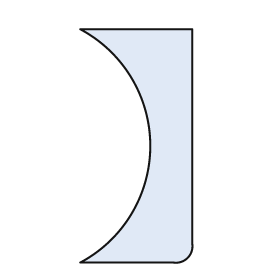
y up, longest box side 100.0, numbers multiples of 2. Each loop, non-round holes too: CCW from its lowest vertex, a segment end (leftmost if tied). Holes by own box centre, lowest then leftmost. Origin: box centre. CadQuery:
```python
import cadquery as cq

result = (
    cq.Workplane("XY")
    .moveTo(-24.0, -50.0)
    .lineTo(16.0, -50.0)
    .threePointArc((22.0, -48.0), (24.0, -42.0))
    .lineTo(24.0, 50.0)
    .lineTo(-24.0, 50.0)
    .threePointArc((6.0, 0.0), (-24.0, -50.0))
    .close()
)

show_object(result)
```